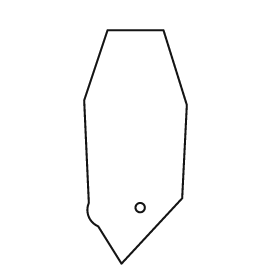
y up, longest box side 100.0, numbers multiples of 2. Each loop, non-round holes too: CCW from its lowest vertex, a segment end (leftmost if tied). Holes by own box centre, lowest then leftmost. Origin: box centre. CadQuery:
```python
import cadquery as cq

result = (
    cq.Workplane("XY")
    .moveTo(-6.0, -50.0)
    .lineTo(20.0, -22.0)
    .lineTo(22.0, 18.0)
    .lineTo(12.0, 50.0)
    .lineTo(-12.0, 50.0)
    .lineTo(-22.0, 20.0)
    .lineTo(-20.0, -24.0)
    .threePointArc((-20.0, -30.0), (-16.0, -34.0))
    .close()
    .moveTo(2.0, -26.0)
    .circle(2.0)
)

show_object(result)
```